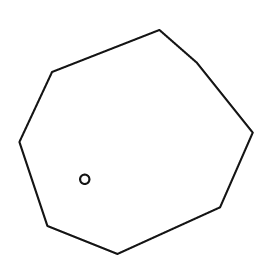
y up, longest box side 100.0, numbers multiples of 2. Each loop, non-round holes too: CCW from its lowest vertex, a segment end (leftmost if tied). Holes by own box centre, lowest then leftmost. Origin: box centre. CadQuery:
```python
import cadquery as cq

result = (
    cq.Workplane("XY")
    .moveTo(-8.0, -48.0)
    .lineTo(36.0, -28.0)
    .lineTo(50.0, 4.0)
    .lineTo(26.0, 34.0)
    .lineTo(10.0, 48.0)
    .lineTo(-36.0, 30.0)
    .lineTo(-50.0, 0.0)
    .lineTo(-38.0, -36.0)
    .close()
    .moveTo(-22.0, -16.0)
    .circle(2.0)
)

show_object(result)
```